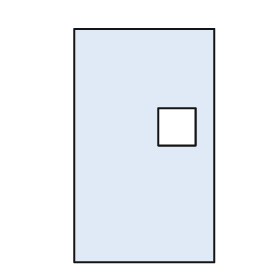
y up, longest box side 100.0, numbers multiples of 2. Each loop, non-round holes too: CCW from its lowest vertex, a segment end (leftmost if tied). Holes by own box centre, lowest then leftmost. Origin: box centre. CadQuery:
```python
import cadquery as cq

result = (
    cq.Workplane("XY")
    .moveTo(-30.0, -50.0)
    .lineTo(30.0, -50.0)
    .lineTo(30.0, 50.0)
    .lineTo(-30.0, 50.0)
    .close()
    .moveTo(6.0, 0.0)
    .lineTo(22.0, 0.0)
    .lineTo(22.0, 16.0)
    .lineTo(6.0, 16.0)
    .close()
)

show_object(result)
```